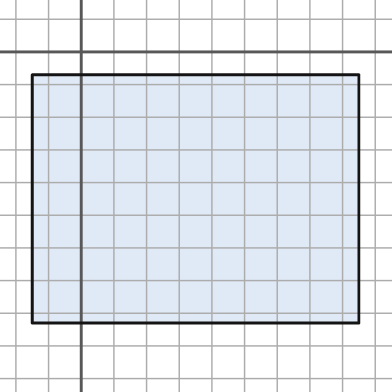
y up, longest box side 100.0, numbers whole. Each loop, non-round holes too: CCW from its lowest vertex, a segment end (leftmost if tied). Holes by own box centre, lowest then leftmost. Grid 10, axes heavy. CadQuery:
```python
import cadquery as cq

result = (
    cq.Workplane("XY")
    .moveTo(-15.0, -83.0)
    .lineTo(85.0, -83.0)
    .lineTo(85.0, -7.0)
    .lineTo(-15.0, -7.0)
    .close()
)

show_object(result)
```